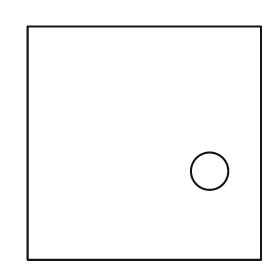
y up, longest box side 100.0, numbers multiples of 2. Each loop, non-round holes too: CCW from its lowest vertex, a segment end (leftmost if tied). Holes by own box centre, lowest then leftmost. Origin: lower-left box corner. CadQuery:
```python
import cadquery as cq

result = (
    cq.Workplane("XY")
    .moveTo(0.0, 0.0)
    .lineTo(100.0, 0.0)
    .lineTo(100.0, 100.0)
    .lineTo(0.0, 100.0)
    .close()
    .moveTo(78.0, 38.0)
    .circle(8.0)
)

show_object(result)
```